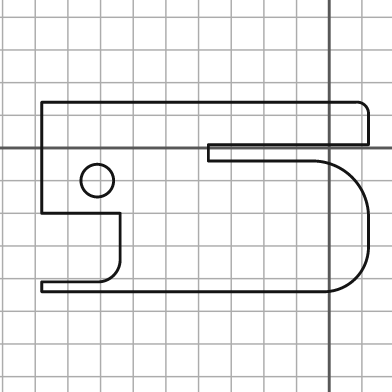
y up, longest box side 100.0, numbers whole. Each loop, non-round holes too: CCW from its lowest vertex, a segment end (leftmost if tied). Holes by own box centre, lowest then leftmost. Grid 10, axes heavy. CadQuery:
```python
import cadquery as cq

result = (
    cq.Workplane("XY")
    .moveTo(-88.0, -44.0)
    .lineTo(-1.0, -44.0)
    .threePointArc((8.0, -40.0), (12.0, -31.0))
    .lineTo(12.0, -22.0)
    .threePointArc((7.0, -9.0), (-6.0, -4.0))
    .lineTo(-37.0, -4.0)
    .lineTo(-37.0, 1.0)
    .lineTo(12.0, 1.0)
    .lineTo(12.0, 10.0)
    .threePointArc((11.0, 13.0), (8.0, 14.0))
    .lineTo(-88.0, 14.0)
    .lineTo(-88.0, -20.0)
    .lineTo(-64.0, -20.0)
    .lineTo(-64.0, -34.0)
    .threePointArc((-66.0, -39.0), (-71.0, -41.0))
    .lineTo(-88.0, -41.0)
    .close()
    .moveTo(-71.0, -10.0)
    .circle(5.0)
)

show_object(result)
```